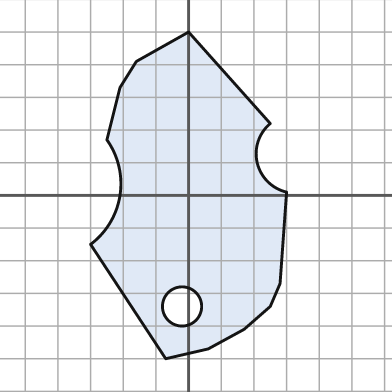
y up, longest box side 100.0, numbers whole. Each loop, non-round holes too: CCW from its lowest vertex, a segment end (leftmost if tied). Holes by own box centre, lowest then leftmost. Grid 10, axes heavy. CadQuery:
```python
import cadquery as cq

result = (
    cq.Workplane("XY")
    .moveTo(-7.0, -50.0)
    .lineTo(6.0, -47.0)
    .lineTo(17.0, -41.0)
    .lineTo(25.0, -34.0)
    .lineTo(28.0, -27.0)
    .lineTo(30.0, 1.0)
    .threePointArc((21.0, 10.0), (25.0, 22.0))
    .lineTo(0.0, 50.0)
    .lineTo(-16.0, 41.0)
    .lineTo(-21.0, 33.0)
    .lineTo(-25.0, 17.0)
    .threePointArc((-21.0, 0.0), (-30.0, -15.0))
    .close()
    .moveTo(-2.0, -34.0)
    .circle(6.0)
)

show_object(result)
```